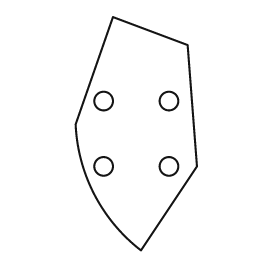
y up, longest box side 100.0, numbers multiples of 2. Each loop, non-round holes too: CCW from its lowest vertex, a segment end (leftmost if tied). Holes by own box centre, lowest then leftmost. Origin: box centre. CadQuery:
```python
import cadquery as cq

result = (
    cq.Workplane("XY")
    .moveTo(2.0, -50.0)
    .lineTo(26.0, -14.0)
    .lineTo(22.0, 38.0)
    .lineTo(-10.0, 50.0)
    .lineTo(-26.0, 4.0)
    .threePointArc((-18.0, -26.0), (2.0, -50.0))
    .close()
    .moveTo(-14.0, -14.0)
    .circle(4.0)
    .moveTo(14.0, -14.0)
    .circle(4.0)
    .moveTo(-14.0, 14.0)
    .circle(4.0)
    .moveTo(14.0, 14.0)
    .circle(4.0)
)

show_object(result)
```